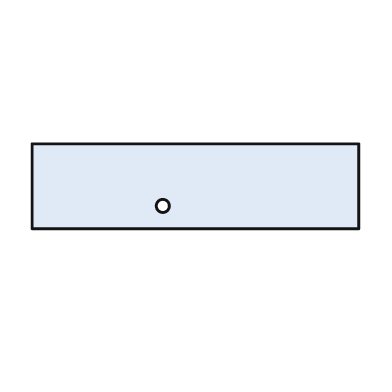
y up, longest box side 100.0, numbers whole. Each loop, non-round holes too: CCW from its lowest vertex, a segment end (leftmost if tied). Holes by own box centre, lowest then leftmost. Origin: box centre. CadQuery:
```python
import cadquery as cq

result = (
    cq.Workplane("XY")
    .moveTo(-50.0, -13.0)
    .lineTo(50.0, -13.0)
    .lineTo(50.0, 13.0)
    .lineTo(-50.0, 13.0)
    .close()
    .moveTo(-10.0, -6.0)
    .circle(2.0)
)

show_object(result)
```